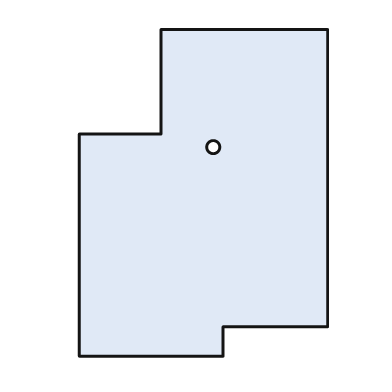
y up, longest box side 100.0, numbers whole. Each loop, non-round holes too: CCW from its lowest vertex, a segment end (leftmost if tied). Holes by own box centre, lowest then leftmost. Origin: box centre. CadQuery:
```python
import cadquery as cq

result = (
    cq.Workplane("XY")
    .moveTo(-38.0, -50.0)
    .lineTo(6.0, -50.0)
    .lineTo(6.0, -41.0)
    .lineTo(38.0, -41.0)
    .lineTo(38.0, 50.0)
    .lineTo(-13.0, 50.0)
    .lineTo(-13.0, 18.0)
    .lineTo(-38.0, 18.0)
    .close()
    .moveTo(3.0, 14.0)
    .circle(2.0)
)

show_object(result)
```